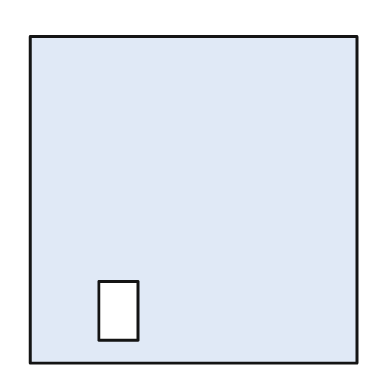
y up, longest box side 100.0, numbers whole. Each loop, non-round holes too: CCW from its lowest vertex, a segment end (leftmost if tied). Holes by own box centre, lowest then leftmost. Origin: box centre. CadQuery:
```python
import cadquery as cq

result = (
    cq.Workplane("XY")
    .moveTo(-50.0, -50.0)
    .lineTo(50.0, -50.0)
    .lineTo(50.0, 50.0)
    .lineTo(-50.0, 50.0)
    .close()
    .moveTo(-29.0, -43.0)
    .lineTo(-17.0, -43.0)
    .lineTo(-17.0, -25.0)
    .lineTo(-29.0, -25.0)
    .close()
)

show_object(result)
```